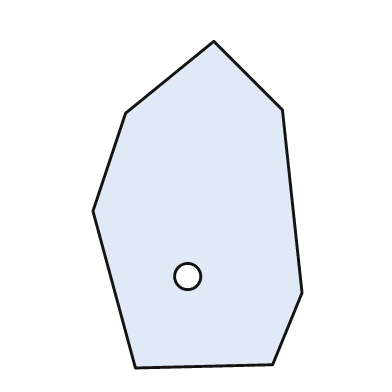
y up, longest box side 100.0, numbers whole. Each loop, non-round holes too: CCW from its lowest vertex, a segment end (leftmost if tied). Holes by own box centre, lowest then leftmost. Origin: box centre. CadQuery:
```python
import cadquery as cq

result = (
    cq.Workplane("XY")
    .moveTo(-19.0, -50.0)
    .lineTo(23.0, -49.0)
    .lineTo(32.0, -27.0)
    .lineTo(26.0, 29.0)
    .lineTo(5.0, 50.0)
    .lineTo(-22.0, 28.0)
    .lineTo(-32.0, -2.0)
    .close()
    .moveTo(-3.0, -22.0)
    .circle(4.0)
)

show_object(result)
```